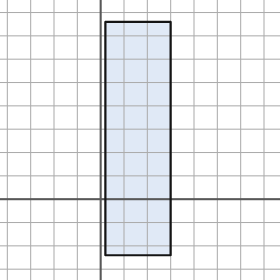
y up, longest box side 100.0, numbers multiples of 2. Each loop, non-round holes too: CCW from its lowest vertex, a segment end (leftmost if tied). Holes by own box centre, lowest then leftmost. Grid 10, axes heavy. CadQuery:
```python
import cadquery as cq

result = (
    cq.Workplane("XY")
    .moveTo(2.0, -24.0)
    .lineTo(30.0, -24.0)
    .lineTo(30.0, 76.0)
    .lineTo(2.0, 76.0)
    .close()
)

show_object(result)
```